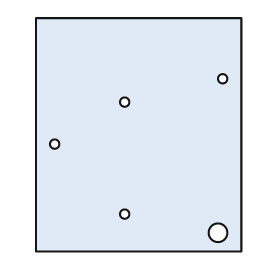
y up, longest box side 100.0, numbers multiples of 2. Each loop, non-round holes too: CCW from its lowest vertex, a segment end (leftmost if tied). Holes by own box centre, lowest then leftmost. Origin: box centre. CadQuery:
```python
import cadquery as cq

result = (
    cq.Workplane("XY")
    .moveTo(-44.0, -50.0)
    .lineTo(44.0, -50.0)
    .lineTo(44.0, 50.0)
    .lineTo(-44.0, 50.0)
    .close()
    .moveTo(34.0, -42.0)
    .circle(4.0)
    .moveTo(-6.0, -34.0)
    .circle(2.0)
    .moveTo(-36.0, -4.0)
    .circle(2.0)
    .moveTo(-6.0, 14.0)
    .circle(2.0)
    .moveTo(36.0, 24.0)
    .circle(2.0)
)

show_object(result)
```